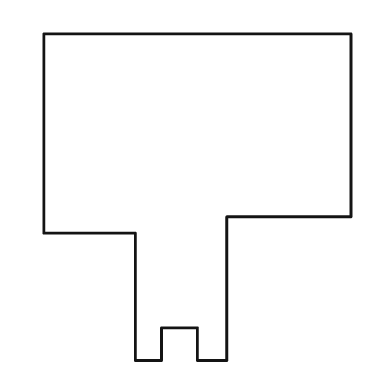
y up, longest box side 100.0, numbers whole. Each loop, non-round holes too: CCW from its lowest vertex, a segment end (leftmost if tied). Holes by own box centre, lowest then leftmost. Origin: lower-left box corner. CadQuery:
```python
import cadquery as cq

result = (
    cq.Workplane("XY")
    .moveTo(28.0, 0.0)
    .lineTo(36.0, 0.0)
    .lineTo(36.0, 10.0)
    .lineTo(47.0, 10.0)
    .lineTo(47.0, 0.0)
    .lineTo(56.0, 0.0)
    .lineTo(56.0, 44.0)
    .lineTo(94.0, 44.0)
    .lineTo(94.0, 100.0)
    .lineTo(0.0, 100.0)
    .lineTo(0.0, 39.0)
    .lineTo(28.0, 39.0)
    .close()
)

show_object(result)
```